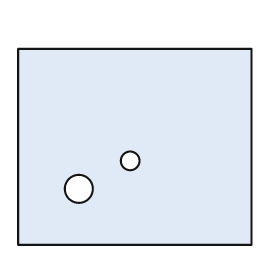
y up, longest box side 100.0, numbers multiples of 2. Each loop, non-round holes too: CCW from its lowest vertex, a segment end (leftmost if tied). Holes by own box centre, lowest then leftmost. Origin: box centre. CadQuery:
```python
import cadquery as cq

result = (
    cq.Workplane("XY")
    .moveTo(-50.0, -42.0)
    .lineTo(50.0, -42.0)
    .lineTo(50.0, 42.0)
    .lineTo(-50.0, 42.0)
    .close()
    .moveTo(-24.0, -18.0)
    .circle(6.0)
    .moveTo(-2.0, -6.0)
    .circle(4.0)
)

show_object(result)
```